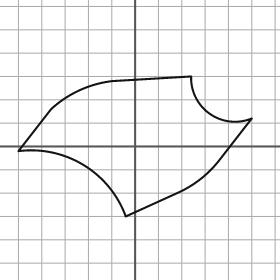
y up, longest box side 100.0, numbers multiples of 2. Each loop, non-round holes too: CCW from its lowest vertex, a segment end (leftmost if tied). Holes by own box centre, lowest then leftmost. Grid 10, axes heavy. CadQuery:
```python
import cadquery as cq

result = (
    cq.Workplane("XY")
    .moveTo(-4.0, -30.0)
    .lineTo(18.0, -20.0)
    .threePointArc((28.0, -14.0), (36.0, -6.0))
    .lineTo(50.0, 12.0)
    .threePointArc((32.0, 14.0), (24.0, 30.0))
    .lineTo(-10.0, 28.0)
    .threePointArc((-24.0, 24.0), (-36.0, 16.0))
    .lineTo(-50.0, -2.0)
    .threePointArc((-22.0, -8.0), (-4.0, -30.0))
    .close()
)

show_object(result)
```